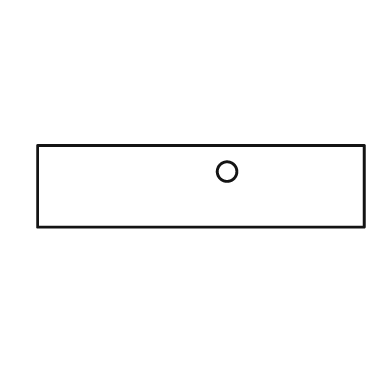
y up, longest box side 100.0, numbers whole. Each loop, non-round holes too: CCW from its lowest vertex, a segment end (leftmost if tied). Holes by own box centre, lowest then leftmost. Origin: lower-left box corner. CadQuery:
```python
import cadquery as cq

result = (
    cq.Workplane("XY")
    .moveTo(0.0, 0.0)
    .lineTo(100.0, 0.0)
    .lineTo(100.0, 25.0)
    .lineTo(0.0, 25.0)
    .close()
    .moveTo(58.0, 17.0)
    .circle(3.0)
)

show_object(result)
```